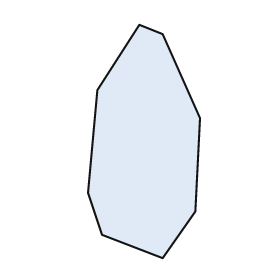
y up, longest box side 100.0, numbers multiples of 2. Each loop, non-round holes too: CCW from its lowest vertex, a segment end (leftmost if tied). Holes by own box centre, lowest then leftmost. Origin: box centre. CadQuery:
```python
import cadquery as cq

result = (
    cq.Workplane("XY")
    .moveTo(8.0, -50.0)
    .lineTo(22.0, -30.0)
    .lineTo(24.0, 10.0)
    .lineTo(8.0, 46.0)
    .lineTo(-2.0, 50.0)
    .lineTo(-20.0, 22.0)
    .lineTo(-24.0, -22.0)
    .lineTo(-18.0, -40.0)
    .close()
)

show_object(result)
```